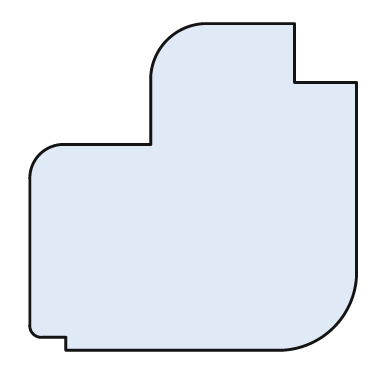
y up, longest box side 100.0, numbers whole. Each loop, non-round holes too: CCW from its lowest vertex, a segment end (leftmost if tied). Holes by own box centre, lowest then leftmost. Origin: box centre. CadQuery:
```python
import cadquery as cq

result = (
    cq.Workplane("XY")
    .moveTo(-39.0, -50.0)
    .lineTo(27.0, -50.0)
    .threePointArc((43.0, -43.0), (50.0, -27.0))
    .lineTo(50.0, 32.0)
    .lineTo(31.0, 32.0)
    .lineTo(31.0, 50.0)
    .lineTo(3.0, 50.0)
    .threePointArc((-8.0, 45.0), (-13.0, 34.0))
    .lineTo(-13.0, 13.0)
    .lineTo(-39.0, 13.0)
    .threePointArc((-47.0, 10.0), (-50.0, 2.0))
    .lineTo(-50.0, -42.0)
    .threePointArc((-49.0, -45.0), (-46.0, -46.0))
    .lineTo(-39.0, -46.0)
    .close()
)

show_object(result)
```